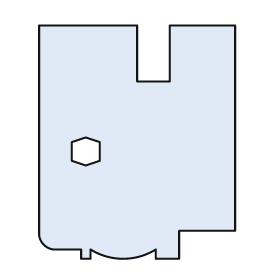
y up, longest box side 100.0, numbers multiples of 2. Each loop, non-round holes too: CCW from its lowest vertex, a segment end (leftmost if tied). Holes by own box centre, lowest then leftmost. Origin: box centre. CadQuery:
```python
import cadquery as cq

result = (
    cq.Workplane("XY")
    .moveTo(-24.0, -50.0)
    .lineTo(-20.0, -50.0)
    .lineTo(-20.0, -46.0)
    .threePointArc((-6.0, -50.0), (8.0, -46.0))
    .lineTo(8.0, -50.0)
    .lineTo(18.0, -50.0)
    .lineTo(18.0, -38.0)
    .lineTo(42.0, -38.0)
    .lineTo(42.0, 50.0)
    .lineTo(14.0, 50.0)
    .lineTo(14.0, 26.0)
    .lineTo(0.0, 26.0)
    .lineTo(0.0, 50.0)
    .lineTo(-42.0, 50.0)
    .lineTo(-42.0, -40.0)
    .threePointArc((-40.0, -44.0), (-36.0, -46.0))
    .lineTo(-24.0, -46.0)
    .close()
    .moveTo(-22.0, -10.0)
    .lineTo(-16.0, -8.0)
    .lineTo(-16.0, 0.0)
    .lineTo(-22.0, 2.0)
    .lineTo(-28.0, 0.0)
    .lineTo(-28.0, -8.0)
    .close()
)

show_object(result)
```